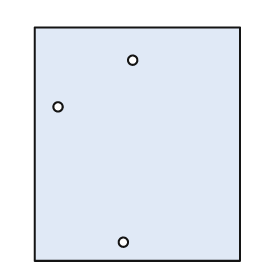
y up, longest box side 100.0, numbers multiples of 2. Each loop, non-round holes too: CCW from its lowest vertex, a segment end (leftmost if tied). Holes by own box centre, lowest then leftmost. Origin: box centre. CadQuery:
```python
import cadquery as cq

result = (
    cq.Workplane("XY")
    .moveTo(-44.0, -50.0)
    .lineTo(44.0, -50.0)
    .lineTo(44.0, 50.0)
    .lineTo(-44.0, 50.0)
    .close()
    .moveTo(-6.0, -42.0)
    .circle(2.0)
    .moveTo(-34.0, 16.0)
    .circle(2.0)
    .moveTo(-2.0, 36.0)
    .circle(2.0)
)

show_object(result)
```